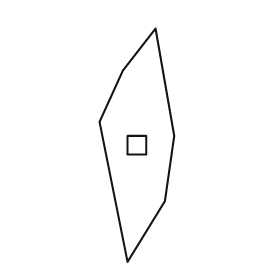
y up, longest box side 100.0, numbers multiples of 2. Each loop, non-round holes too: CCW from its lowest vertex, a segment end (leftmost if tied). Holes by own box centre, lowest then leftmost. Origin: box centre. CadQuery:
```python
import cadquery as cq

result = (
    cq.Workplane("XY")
    .moveTo(-4.0, -50.0)
    .lineTo(12.0, -24.0)
    .lineTo(16.0, 4.0)
    .lineTo(8.0, 50.0)
    .lineTo(-6.0, 32.0)
    .lineTo(-16.0, 10.0)
    .close()
    .moveTo(-4.0, -4.0)
    .lineTo(4.0, -4.0)
    .lineTo(4.0, 4.0)
    .lineTo(-4.0, 4.0)
    .close()
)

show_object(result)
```